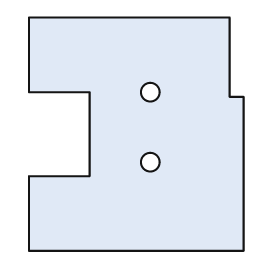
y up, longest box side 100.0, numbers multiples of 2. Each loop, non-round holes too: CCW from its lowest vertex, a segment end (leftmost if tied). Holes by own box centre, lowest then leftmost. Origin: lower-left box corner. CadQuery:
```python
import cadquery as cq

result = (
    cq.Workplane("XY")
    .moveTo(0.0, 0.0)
    .lineTo(92.0, 0.0)
    .lineTo(92.0, 66.0)
    .lineTo(86.0, 66.0)
    .lineTo(86.0, 100.0)
    .lineTo(0.0, 100.0)
    .lineTo(0.0, 68.0)
    .lineTo(26.0, 68.0)
    .lineTo(26.0, 32.0)
    .lineTo(0.0, 32.0)
    .close()
    .moveTo(52.0, 38.0)
    .circle(4.0)
    .moveTo(52.0, 68.0)
    .circle(4.0)
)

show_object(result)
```